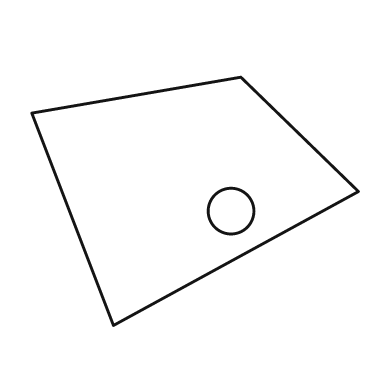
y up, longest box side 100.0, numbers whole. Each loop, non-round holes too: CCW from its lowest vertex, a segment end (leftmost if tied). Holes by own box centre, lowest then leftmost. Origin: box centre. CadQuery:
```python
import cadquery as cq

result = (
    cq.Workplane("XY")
    .moveTo(-25.0, -38.0)
    .lineTo(50.0, 3.0)
    .lineTo(14.0, 38.0)
    .lineTo(-50.0, 27.0)
    .close()
    .moveTo(11.0, -3.0)
    .circle(7.0)
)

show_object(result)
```